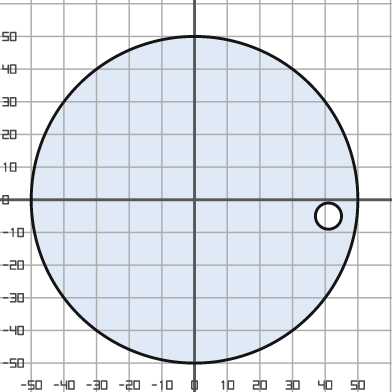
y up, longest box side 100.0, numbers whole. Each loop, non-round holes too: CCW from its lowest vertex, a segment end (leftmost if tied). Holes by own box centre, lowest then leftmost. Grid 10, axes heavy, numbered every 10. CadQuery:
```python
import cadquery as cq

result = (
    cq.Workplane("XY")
    .moveTo(0.0, 0.0)
    .circle(50.0)
    .moveTo(41.0, -5.0)
    .circle(4.0)
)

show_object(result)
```